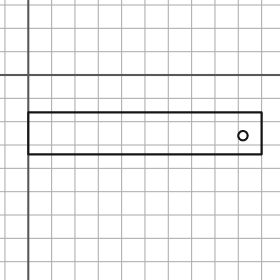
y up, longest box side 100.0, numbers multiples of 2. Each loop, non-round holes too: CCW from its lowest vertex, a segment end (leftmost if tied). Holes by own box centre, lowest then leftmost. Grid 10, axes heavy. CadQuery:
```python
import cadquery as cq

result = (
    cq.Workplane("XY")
    .moveTo(0.0, -34.0)
    .lineTo(100.0, -34.0)
    .lineTo(100.0, -16.0)
    .lineTo(0.0, -16.0)
    .close()
    .moveTo(92.0, -26.0)
    .circle(2.0)
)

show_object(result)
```